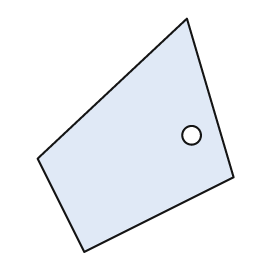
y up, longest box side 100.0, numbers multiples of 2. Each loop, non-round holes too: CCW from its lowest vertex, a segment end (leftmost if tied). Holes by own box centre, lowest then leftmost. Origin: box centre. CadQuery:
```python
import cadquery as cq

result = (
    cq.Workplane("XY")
    .moveTo(-22.0, -50.0)
    .lineTo(42.0, -18.0)
    .lineTo(22.0, 50.0)
    .lineTo(-42.0, -10.0)
    .close()
    .moveTo(24.0, 0.0)
    .circle(4.0)
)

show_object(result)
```